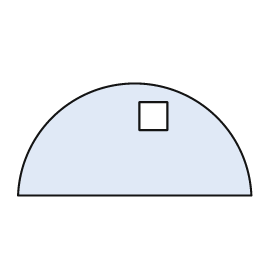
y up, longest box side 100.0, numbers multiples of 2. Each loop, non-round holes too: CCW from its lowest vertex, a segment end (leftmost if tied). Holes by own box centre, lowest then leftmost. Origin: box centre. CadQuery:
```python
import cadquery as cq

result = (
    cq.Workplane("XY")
    .moveTo(-50.0, -24.0)
    .lineTo(50.0, -24.0)
    .threePointArc((0.0, 24.0), (-50.0, -24.0))
    .close()
    .moveTo(2.0, 4.0)
    .lineTo(14.0, 4.0)
    .lineTo(14.0, 16.0)
    .lineTo(2.0, 16.0)
    .close()
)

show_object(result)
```